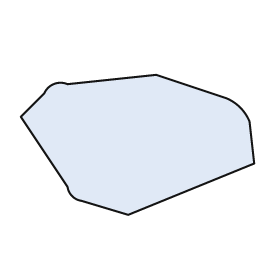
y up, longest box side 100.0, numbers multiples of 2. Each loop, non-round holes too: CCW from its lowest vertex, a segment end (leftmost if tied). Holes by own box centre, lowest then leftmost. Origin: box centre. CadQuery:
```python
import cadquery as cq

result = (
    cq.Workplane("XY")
    .moveTo(-4.0, -30.0)
    .lineTo(50.0, -8.0)
    .lineTo(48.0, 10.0)
    .threePointArc((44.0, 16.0), (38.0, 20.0))
    .lineTo(8.0, 30.0)
    .lineTo(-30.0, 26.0)
    .threePointArc((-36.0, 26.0), (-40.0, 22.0))
    .lineTo(-50.0, 12.0)
    .lineTo(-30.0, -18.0)
    .threePointArc((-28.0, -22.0), (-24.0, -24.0))
    .close()
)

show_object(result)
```